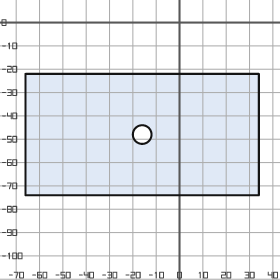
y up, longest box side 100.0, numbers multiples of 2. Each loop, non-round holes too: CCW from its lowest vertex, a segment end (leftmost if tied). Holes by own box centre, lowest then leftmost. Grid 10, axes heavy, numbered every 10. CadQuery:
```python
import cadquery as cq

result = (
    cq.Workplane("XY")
    .moveTo(-66.0, -74.0)
    .lineTo(34.0, -74.0)
    .lineTo(34.0, -22.0)
    .lineTo(-66.0, -22.0)
    .close()
    .moveTo(-16.0, -48.0)
    .circle(4.0)
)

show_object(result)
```